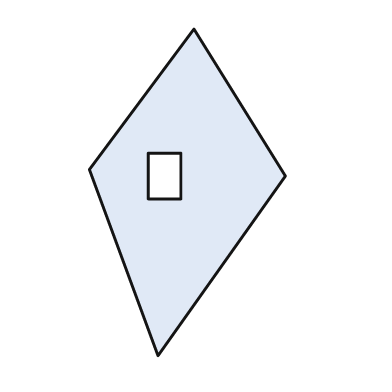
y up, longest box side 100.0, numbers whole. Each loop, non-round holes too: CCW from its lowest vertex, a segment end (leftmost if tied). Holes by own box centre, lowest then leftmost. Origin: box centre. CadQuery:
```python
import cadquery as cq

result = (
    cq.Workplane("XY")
    .moveTo(-9.0, -50.0)
    .lineTo(30.0, 5.0)
    .lineTo(2.0, 50.0)
    .lineTo(-30.0, 7.0)
    .close()
    .moveTo(-12.0, -2.0)
    .lineTo(-2.0, -2.0)
    .lineTo(-2.0, 12.0)
    .lineTo(-12.0, 12.0)
    .close()
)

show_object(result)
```